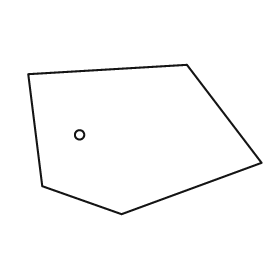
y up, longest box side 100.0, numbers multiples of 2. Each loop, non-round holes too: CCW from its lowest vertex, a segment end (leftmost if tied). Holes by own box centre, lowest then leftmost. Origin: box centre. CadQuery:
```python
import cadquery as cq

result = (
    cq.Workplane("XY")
    .moveTo(-10.0, -32.0)
    .lineTo(50.0, -10.0)
    .lineTo(18.0, 32.0)
    .lineTo(-50.0, 28.0)
    .lineTo(-44.0, -20.0)
    .close()
    .moveTo(-28.0, 2.0)
    .circle(2.0)
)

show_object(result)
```